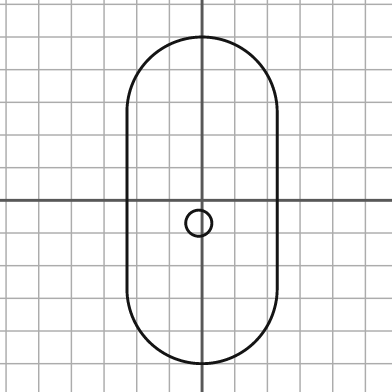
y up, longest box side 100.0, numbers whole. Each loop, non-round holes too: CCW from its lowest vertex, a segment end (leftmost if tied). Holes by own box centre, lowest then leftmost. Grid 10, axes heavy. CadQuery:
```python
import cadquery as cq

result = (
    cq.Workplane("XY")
    .moveTo(-23.0, -27.0)
    .threePointArc((0.0, -50.0), (23.0, -27.0))
    .lineTo(23.0, 27.0)
    .threePointArc((0.0, 50.0), (-23.0, 27.0))
    .close()
    .moveTo(-1.0, -7.0)
    .circle(4.0)
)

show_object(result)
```